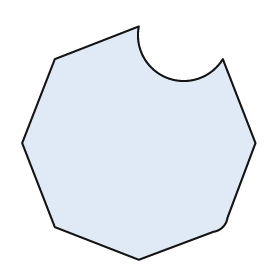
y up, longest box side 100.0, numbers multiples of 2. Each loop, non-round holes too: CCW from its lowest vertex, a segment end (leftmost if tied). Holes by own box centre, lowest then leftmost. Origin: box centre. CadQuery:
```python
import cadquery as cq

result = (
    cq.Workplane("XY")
    .moveTo(0.0, -50.0)
    .lineTo(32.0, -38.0)
    .threePointArc((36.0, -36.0), (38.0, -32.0))
    .lineTo(50.0, 0.0)
    .lineTo(36.0, 36.0)
    .threePointArc((12.0, 28.0), (0.0, 50.0))
    .lineTo(-36.0, 36.0)
    .lineTo(-50.0, 0.0)
    .lineTo(-36.0, -36.0)
    .close()
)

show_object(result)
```